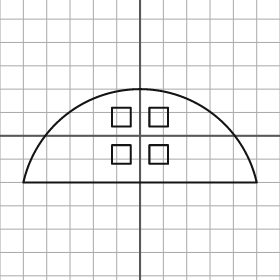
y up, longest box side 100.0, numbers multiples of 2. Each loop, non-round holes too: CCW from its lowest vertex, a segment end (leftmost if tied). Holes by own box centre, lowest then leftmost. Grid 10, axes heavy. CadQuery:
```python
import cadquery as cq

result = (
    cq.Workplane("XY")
    .moveTo(-50.0, -20.0)
    .lineTo(50.0, -20.0)
    .threePointArc((0.0, 20.0), (-50.0, -20.0))
    .close()
    .moveTo(-12.0, -12.0)
    .lineTo(-4.0, -12.0)
    .lineTo(-4.0, -4.0)
    .lineTo(-12.0, -4.0)
    .close()
    .moveTo(4.0, -12.0)
    .lineTo(12.0, -12.0)
    .lineTo(12.0, -4.0)
    .lineTo(4.0, -4.0)
    .close()
    .moveTo(-12.0, 4.0)
    .lineTo(-4.0, 4.0)
    .lineTo(-4.0, 12.0)
    .lineTo(-12.0, 12.0)
    .close()
    .moveTo(4.0, 4.0)
    .lineTo(12.0, 4.0)
    .lineTo(12.0, 12.0)
    .lineTo(4.0, 12.0)
    .close()
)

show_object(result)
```